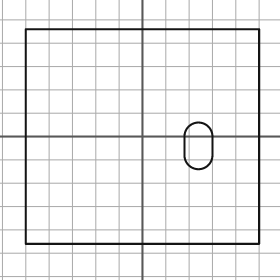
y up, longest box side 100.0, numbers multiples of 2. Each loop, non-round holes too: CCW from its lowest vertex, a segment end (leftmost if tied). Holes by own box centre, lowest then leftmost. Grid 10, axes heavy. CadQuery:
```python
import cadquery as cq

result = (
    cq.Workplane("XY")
    .moveTo(-50.0, -46.0)
    .lineTo(50.0, -46.0)
    .lineTo(50.0, 46.0)
    .lineTo(-50.0, 46.0)
    .close()
    .moveTo(18.0, -8.0)
    .threePointArc((24.0, -14.0), (30.0, -8.0))
    .lineTo(30.0, 0.0)
    .threePointArc((24.0, 6.0), (18.0, 0.0))
    .close()
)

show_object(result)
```